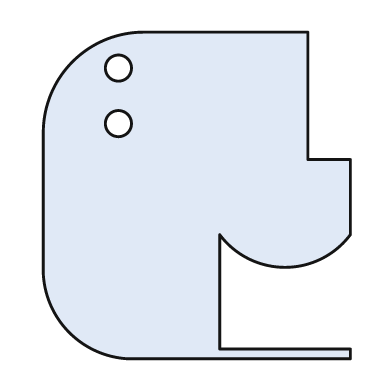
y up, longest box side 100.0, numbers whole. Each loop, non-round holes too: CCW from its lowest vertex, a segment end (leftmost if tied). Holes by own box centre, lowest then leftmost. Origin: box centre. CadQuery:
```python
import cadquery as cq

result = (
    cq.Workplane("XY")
    .moveTo(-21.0, -50.0)
    .lineTo(47.0, -50.0)
    .lineTo(47.0, -47.0)
    .lineTo(7.0, -47.0)
    .lineTo(7.0, -12.0)
    .threePointArc((27.0, -22.0), (47.0, -12.0))
    .lineTo(47.0, 11.0)
    .lineTo(34.0, 11.0)
    .lineTo(34.0, 50.0)
    .lineTo(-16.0, 50.0)
    .threePointArc((-38.0, 41.0), (-47.0, 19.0))
    .lineTo(-47.0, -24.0)
    .threePointArc((-39.0, -42.0), (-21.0, -50.0))
    .close()
    .moveTo(-24.0, 22.0)
    .circle(4.0)
    .moveTo(-24.0, 39.0)
    .circle(4.0)
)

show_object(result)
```